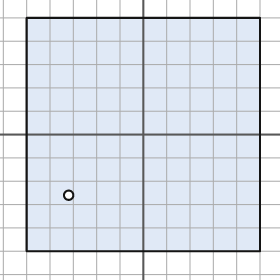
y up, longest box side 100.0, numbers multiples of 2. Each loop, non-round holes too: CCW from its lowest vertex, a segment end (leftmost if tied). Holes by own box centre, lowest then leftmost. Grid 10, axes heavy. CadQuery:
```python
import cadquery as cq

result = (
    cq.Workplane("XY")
    .moveTo(-50.0, -50.0)
    .lineTo(50.0, -50.0)
    .lineTo(50.0, 50.0)
    .lineTo(-50.0, 50.0)
    .close()
    .moveTo(-32.0, -26.0)
    .circle(2.0)
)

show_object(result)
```